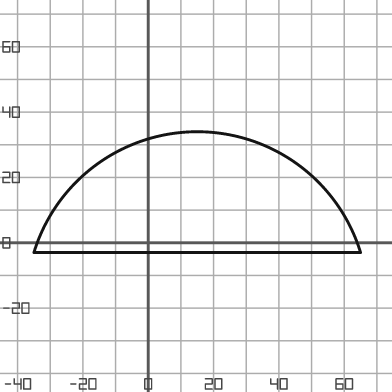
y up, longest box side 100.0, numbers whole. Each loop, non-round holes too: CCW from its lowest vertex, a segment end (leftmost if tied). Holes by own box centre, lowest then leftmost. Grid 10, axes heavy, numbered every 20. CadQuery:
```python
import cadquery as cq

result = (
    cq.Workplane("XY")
    .moveTo(-35.0, -3.0)
    .lineTo(65.0, -3.0)
    .threePointArc((15.0, 34.0), (-35.0, -3.0))
    .close()
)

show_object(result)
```